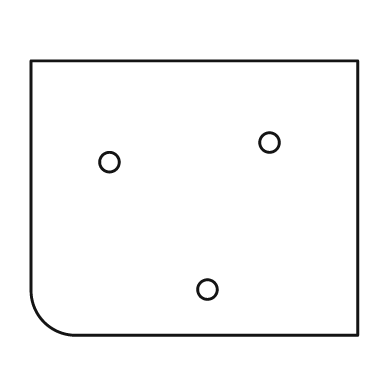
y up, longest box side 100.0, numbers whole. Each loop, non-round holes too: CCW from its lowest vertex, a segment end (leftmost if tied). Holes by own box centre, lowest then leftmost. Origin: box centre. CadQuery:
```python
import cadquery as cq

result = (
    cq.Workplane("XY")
    .moveTo(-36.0, -42.0)
    .lineTo(50.0, -42.0)
    .lineTo(50.0, 42.0)
    .lineTo(-50.0, 42.0)
    .lineTo(-50.0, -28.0)
    .threePointArc((-46.0, -38.0), (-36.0, -42.0))
    .close()
    .moveTo(4.0, -28.0)
    .circle(3.0)
    .moveTo(-26.0, 11.0)
    .circle(3.0)
    .moveTo(23.0, 17.0)
    .circle(3.0)
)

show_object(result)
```